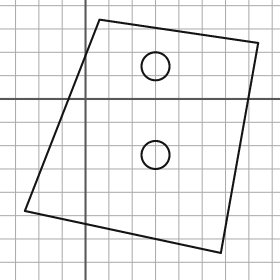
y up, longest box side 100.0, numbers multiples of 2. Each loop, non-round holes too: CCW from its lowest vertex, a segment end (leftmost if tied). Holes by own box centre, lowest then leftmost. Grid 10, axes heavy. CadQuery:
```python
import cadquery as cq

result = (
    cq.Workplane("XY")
    .moveTo(58.0, -66.0)
    .lineTo(74.0, 24.0)
    .lineTo(6.0, 34.0)
    .lineTo(-26.0, -48.0)
    .close()
    .moveTo(30.0, -24.0)
    .circle(6.0)
    .moveTo(30.0, 14.0)
    .circle(6.0)
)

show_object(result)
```